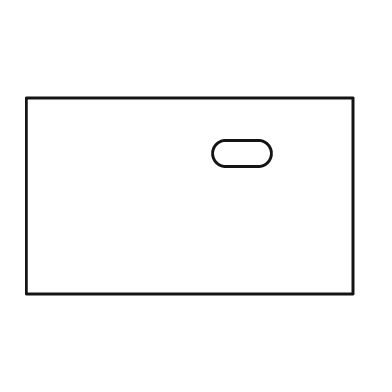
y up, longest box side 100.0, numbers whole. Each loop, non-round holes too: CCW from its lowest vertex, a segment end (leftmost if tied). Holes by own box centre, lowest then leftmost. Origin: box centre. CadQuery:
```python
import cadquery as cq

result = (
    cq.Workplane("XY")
    .moveTo(-50.0, -30.0)
    .lineTo(50.0, -30.0)
    .lineTo(50.0, 30.0)
    .lineTo(-50.0, 30.0)
    .close()
    .moveTo(11.0, 9.0)
    .lineTo(21.0, 9.0)
    .threePointArc((25.0, 13.0), (21.0, 17.0))
    .lineTo(11.0, 17.0)
    .threePointArc((7.0, 13.0), (11.0, 9.0))
    .close()
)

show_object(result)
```